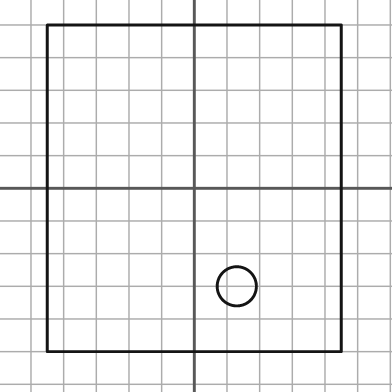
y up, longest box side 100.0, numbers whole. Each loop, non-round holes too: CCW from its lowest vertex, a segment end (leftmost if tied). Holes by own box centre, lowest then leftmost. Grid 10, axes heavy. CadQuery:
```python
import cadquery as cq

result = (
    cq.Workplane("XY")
    .moveTo(-45.0, -50.0)
    .lineTo(45.0, -50.0)
    .lineTo(45.0, 50.0)
    .lineTo(-45.0, 50.0)
    .close()
    .moveTo(13.0, -30.0)
    .circle(6.0)
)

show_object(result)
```